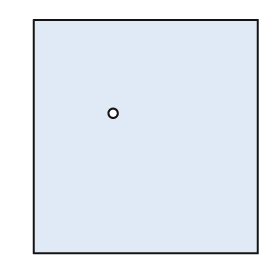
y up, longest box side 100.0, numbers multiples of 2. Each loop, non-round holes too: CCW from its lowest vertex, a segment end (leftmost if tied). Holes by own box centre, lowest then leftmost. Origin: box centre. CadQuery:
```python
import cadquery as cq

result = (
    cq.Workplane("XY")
    .moveTo(-48.0, -50.0)
    .lineTo(48.0, -50.0)
    .lineTo(48.0, 50.0)
    .lineTo(-48.0, 50.0)
    .close()
    .moveTo(-14.0, 10.0)
    .circle(2.0)
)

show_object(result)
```